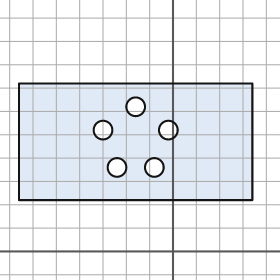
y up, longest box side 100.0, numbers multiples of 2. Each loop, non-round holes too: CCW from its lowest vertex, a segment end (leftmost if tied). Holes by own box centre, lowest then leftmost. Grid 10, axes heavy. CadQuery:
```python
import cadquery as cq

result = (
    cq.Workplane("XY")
    .moveTo(-66.0, 22.0)
    .lineTo(34.0, 22.0)
    .lineTo(34.0, 72.0)
    .lineTo(-66.0, 72.0)
    .close()
    .moveTo(-24.0, 36.0)
    .circle(4.0)
    .moveTo(-8.0, 36.0)
    .circle(4.0)
    .moveTo(-30.0, 52.0)
    .circle(4.0)
    .moveTo(-2.0, 52.0)
    .circle(4.0)
    .moveTo(-16.0, 62.0)
    .circle(4.0)
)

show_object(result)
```